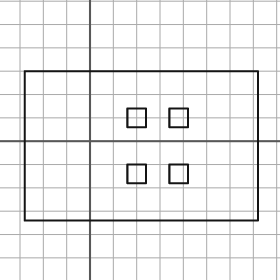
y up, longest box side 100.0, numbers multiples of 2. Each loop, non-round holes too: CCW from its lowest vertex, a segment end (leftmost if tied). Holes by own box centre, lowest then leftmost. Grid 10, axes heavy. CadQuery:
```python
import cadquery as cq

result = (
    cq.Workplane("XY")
    .moveTo(-28.0, -34.0)
    .lineTo(72.0, -34.0)
    .lineTo(72.0, 30.0)
    .lineTo(-28.0, 30.0)
    .close()
    .moveTo(16.0, -18.0)
    .lineTo(24.0, -18.0)
    .lineTo(24.0, -10.0)
    .lineTo(16.0, -10.0)
    .close()
    .moveTo(34.0, -18.0)
    .lineTo(42.0, -18.0)
    .lineTo(42.0, -10.0)
    .lineTo(34.0, -10.0)
    .close()
    .moveTo(16.0, 6.0)
    .lineTo(24.0, 6.0)
    .lineTo(24.0, 14.0)
    .lineTo(16.0, 14.0)
    .close()
    .moveTo(34.0, 6.0)
    .lineTo(42.0, 6.0)
    .lineTo(42.0, 14.0)
    .lineTo(34.0, 14.0)
    .close()
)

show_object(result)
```